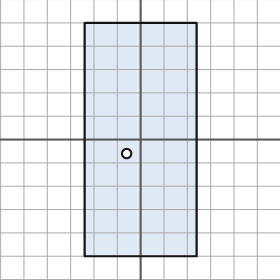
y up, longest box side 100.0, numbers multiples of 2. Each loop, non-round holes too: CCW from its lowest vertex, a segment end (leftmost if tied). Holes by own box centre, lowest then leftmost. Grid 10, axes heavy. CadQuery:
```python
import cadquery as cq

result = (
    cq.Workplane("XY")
    .moveTo(-24.0, -50.0)
    .lineTo(24.0, -50.0)
    .lineTo(24.0, 50.0)
    .lineTo(-24.0, 50.0)
    .close()
    .moveTo(-6.0, -6.0)
    .circle(2.0)
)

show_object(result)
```